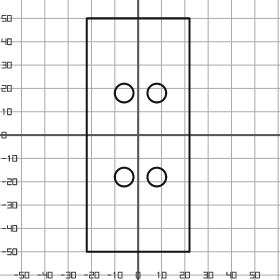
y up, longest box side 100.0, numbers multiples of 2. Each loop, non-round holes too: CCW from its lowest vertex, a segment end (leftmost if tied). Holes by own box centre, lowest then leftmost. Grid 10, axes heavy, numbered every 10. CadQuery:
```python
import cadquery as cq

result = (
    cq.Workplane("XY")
    .moveTo(-22.0, -50.0)
    .lineTo(22.0, -50.0)
    .lineTo(22.0, 50.0)
    .lineTo(-22.0, 50.0)
    .close()
    .moveTo(-6.0, -18.0)
    .circle(4.0)
    .moveTo(8.0, -18.0)
    .circle(4.0)
    .moveTo(-6.0, 18.0)
    .circle(4.0)
    .moveTo(8.0, 18.0)
    .circle(4.0)
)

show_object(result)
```